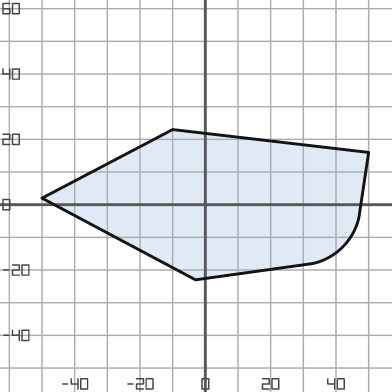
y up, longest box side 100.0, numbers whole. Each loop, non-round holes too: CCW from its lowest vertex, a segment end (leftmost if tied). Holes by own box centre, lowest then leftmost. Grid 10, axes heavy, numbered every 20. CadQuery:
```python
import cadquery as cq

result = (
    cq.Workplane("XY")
    .moveTo(-3.0, -23.0)
    .lineTo(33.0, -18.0)
    .threePointArc((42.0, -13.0), (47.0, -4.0))
    .lineTo(50.0, 16.0)
    .lineTo(-10.0, 23.0)
    .lineTo(-50.0, 2.0)
    .close()
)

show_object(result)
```